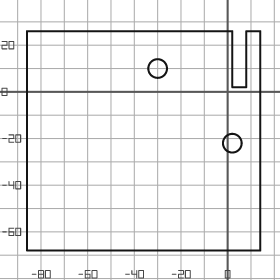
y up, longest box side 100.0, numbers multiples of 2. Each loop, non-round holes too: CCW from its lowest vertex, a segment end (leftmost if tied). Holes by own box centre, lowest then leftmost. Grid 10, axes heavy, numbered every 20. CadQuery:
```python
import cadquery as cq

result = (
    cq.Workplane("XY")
    .moveTo(-86.0, -68.0)
    .lineTo(14.0, -68.0)
    .lineTo(14.0, 26.0)
    .lineTo(8.0, 26.0)
    .lineTo(8.0, 2.0)
    .lineTo(2.0, 2.0)
    .lineTo(2.0, 26.0)
    .lineTo(-86.0, 26.0)
    .close()
    .moveTo(2.0, -22.0)
    .circle(4.0)
    .moveTo(-30.0, 10.0)
    .circle(4.0)
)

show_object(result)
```